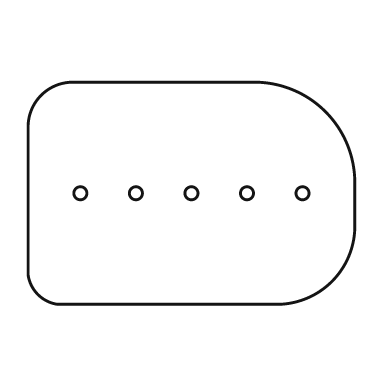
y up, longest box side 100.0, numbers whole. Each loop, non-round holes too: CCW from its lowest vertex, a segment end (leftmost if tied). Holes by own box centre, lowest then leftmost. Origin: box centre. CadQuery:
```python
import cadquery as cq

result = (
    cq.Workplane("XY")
    .moveTo(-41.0, -34.0)
    .lineTo(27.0, -34.0)
    .threePointArc((43.0, -27.0), (50.0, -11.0))
    .lineTo(50.0, 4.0)
    .threePointArc((41.0, 25.0), (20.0, 34.0))
    .lineTo(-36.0, 34.0)
    .threePointArc((-46.0, 30.0), (-50.0, 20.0))
    .lineTo(-50.0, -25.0)
    .threePointArc((-47.0, -31.0), (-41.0, -34.0))
    .close()
    .moveTo(-34.0, 0.0)
    .circle(2.0)
    .moveTo(-17.0, 0.0)
    .circle(2.0)
    .moveTo(0.0, 0.0)
    .circle(2.0)
    .moveTo(17.0, 0.0)
    .circle(2.0)
    .moveTo(34.0, 0.0)
    .circle(2.0)
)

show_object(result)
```